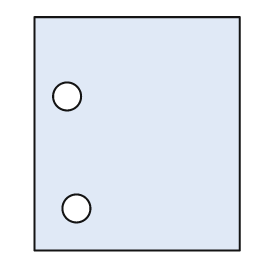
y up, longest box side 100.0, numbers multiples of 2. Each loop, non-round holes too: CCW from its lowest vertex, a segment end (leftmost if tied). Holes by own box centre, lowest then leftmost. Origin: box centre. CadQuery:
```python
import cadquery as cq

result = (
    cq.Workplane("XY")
    .moveTo(-44.0, -50.0)
    .lineTo(44.0, -50.0)
    .lineTo(44.0, 50.0)
    .lineTo(-44.0, 50.0)
    .close()
    .moveTo(-26.0, -32.0)
    .circle(6.0)
    .moveTo(-30.0, 16.0)
    .circle(6.0)
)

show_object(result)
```